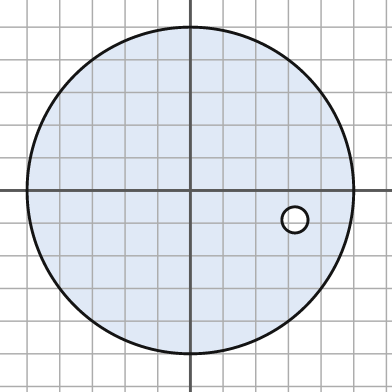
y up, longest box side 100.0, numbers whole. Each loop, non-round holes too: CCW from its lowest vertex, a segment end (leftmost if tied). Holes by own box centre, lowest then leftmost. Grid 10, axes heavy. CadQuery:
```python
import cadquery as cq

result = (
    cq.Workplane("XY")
    .moveTo(0.0, 0.0)
    .circle(50.0)
    .moveTo(32.0, -9.0)
    .circle(4.0)
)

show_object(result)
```